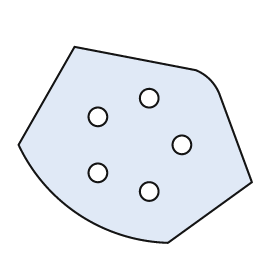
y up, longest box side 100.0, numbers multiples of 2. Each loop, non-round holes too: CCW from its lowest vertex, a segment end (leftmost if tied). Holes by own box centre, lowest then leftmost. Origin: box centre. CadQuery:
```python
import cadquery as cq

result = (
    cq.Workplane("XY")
    .moveTo(14.0, -42.0)
    .lineTo(50.0, -16.0)
    .lineTo(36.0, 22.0)
    .threePointArc((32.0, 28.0), (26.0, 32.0))
    .lineTo(-26.0, 42.0)
    .lineTo(-50.0, 0.0)
    .threePointArc((-24.0, -30.0), (14.0, -42.0))
    .close()
    .moveTo(6.0, -20.0)
    .circle(4.0)
    .moveTo(-16.0, -12.0)
    .circle(4.0)
    .moveTo(20.0, 0.0)
    .circle(4.0)
    .moveTo(-16.0, 12.0)
    .circle(4.0)
    .moveTo(6.0, 20.0)
    .circle(4.0)
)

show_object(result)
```